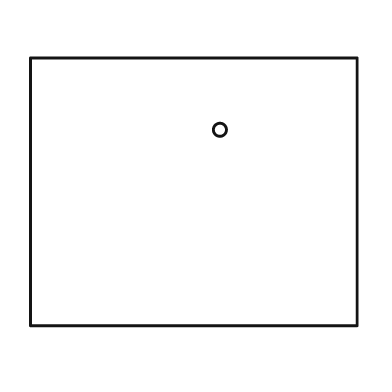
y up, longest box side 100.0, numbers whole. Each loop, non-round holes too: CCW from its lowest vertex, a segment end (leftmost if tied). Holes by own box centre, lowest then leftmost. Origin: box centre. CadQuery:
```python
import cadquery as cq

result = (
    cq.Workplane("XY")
    .moveTo(-50.0, -41.0)
    .lineTo(50.0, -41.0)
    .lineTo(50.0, 41.0)
    .lineTo(-50.0, 41.0)
    .close()
    .moveTo(8.0, 19.0)
    .circle(2.0)
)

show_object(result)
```